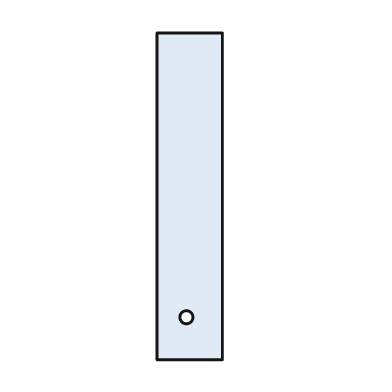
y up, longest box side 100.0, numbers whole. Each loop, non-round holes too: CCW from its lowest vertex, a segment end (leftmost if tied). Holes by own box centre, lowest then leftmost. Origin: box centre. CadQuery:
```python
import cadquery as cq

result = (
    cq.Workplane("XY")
    .moveTo(-10.0, -50.0)
    .lineTo(10.0, -50.0)
    .lineTo(10.0, 50.0)
    .lineTo(-10.0, 50.0)
    .close()
    .moveTo(-1.0, -37.0)
    .circle(2.0)
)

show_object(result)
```